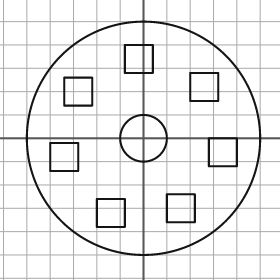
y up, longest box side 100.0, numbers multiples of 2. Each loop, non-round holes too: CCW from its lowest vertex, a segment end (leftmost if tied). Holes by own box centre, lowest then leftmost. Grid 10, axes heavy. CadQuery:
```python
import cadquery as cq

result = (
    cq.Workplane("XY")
    .moveTo(0.0, 0.0)
    .circle(50.0)
    .moveTo(-20.0, -38.0)
    .lineTo(-8.0, -38.0)
    .lineTo(-8.0, -26.0)
    .lineTo(-20.0, -26.0)
    .close()
    .moveTo(10.0, -36.0)
    .lineTo(22.0, -36.0)
    .lineTo(22.0, -24.0)
    .lineTo(10.0, -24.0)
    .close()
    .moveTo(-40.0, -14.0)
    .lineTo(-28.0, -14.0)
    .lineTo(-28.0, -2.0)
    .lineTo(-40.0, -2.0)
    .close()
    .moveTo(28.0, -12.0)
    .lineTo(40.0, -12.0)
    .lineTo(40.0, 0.0)
    .lineTo(28.0, 0.0)
    .close()
    .moveTo(0.0, 0.0)
    .circle(10.0)
    .moveTo(-34.0, 14.0)
    .lineTo(-22.0, 14.0)
    .lineTo(-22.0, 26.0)
    .lineTo(-34.0, 26.0)
    .close()
    .moveTo(20.0, 16.0)
    .lineTo(32.0, 16.0)
    .lineTo(32.0, 28.0)
    .lineTo(20.0, 28.0)
    .close()
    .moveTo(-8.0, 28.0)
    .lineTo(4.0, 28.0)
    .lineTo(4.0, 40.0)
    .lineTo(-8.0, 40.0)
    .close()
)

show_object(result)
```